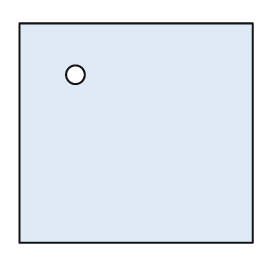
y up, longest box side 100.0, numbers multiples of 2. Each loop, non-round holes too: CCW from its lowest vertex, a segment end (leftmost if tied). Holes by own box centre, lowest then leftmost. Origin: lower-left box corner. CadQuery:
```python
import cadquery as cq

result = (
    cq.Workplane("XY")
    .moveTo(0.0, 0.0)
    .lineTo(100.0, 0.0)
    .lineTo(100.0, 94.0)
    .lineTo(0.0, 94.0)
    .close()
    .moveTo(24.0, 72.0)
    .circle(4.0)
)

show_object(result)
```